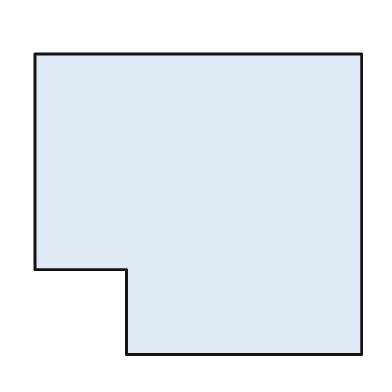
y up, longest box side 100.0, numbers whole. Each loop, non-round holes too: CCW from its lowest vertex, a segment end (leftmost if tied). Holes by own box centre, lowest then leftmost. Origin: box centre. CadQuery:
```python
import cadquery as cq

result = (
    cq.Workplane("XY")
    .moveTo(-22.0, -46.0)
    .lineTo(50.0, -46.0)
    .lineTo(50.0, 46.0)
    .lineTo(-50.0, 46.0)
    .lineTo(-50.0, -20.0)
    .lineTo(-22.0, -20.0)
    .close()
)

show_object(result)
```